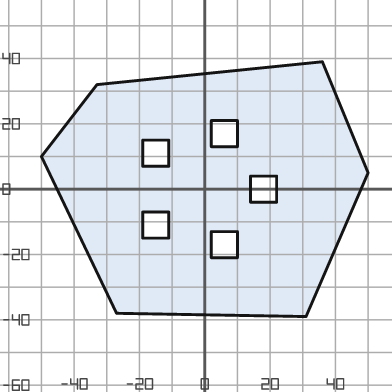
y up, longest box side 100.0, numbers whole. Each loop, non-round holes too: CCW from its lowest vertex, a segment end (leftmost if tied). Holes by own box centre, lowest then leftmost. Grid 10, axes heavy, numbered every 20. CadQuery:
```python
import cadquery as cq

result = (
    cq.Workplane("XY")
    .moveTo(31.0, -39.0)
    .lineTo(50.0, 5.0)
    .lineTo(36.0, 39.0)
    .lineTo(-33.0, 32.0)
    .lineTo(-50.0, 10.0)
    .lineTo(-27.0, -38.0)
    .close()
    .moveTo(2.0, -21.0)
    .lineTo(10.0, -21.0)
    .lineTo(10.0, -13.0)
    .lineTo(2.0, -13.0)
    .close()
    .moveTo(-19.0, -15.0)
    .lineTo(-11.0, -15.0)
    .lineTo(-11.0, -7.0)
    .lineTo(-19.0, -7.0)
    .close()
    .moveTo(14.0, -4.0)
    .lineTo(22.0, -4.0)
    .lineTo(22.0, 4.0)
    .lineTo(14.0, 4.0)
    .close()
    .moveTo(-19.0, 7.0)
    .lineTo(-11.0, 7.0)
    .lineTo(-11.0, 15.0)
    .lineTo(-19.0, 15.0)
    .close()
    .moveTo(2.0, 13.0)
    .lineTo(10.0, 13.0)
    .lineTo(10.0, 21.0)
    .lineTo(2.0, 21.0)
    .close()
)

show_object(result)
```